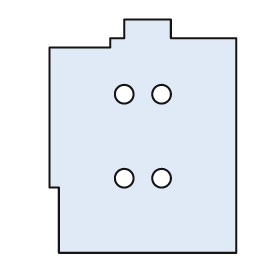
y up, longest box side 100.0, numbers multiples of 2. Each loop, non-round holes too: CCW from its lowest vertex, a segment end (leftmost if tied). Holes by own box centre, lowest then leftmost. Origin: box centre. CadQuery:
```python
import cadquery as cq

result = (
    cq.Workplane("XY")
    .moveTo(-36.0, -50.0)
    .lineTo(40.0, -50.0)
    .lineTo(40.0, 42.0)
    .lineTo(12.0, 42.0)
    .lineTo(12.0, 50.0)
    .lineTo(-8.0, 50.0)
    .lineTo(-8.0, 42.0)
    .lineTo(-14.0, 42.0)
    .lineTo(-14.0, 38.0)
    .lineTo(-40.0, 38.0)
    .lineTo(-40.0, -22.0)
    .lineTo(-36.0, -22.0)
    .close()
    .moveTo(-8.0, -18.0)
    .circle(4.0)
    .moveTo(8.0, -18.0)
    .circle(4.0)
    .moveTo(-8.0, 18.0)
    .circle(4.0)
    .moveTo(8.0, 18.0)
    .circle(4.0)
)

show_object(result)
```